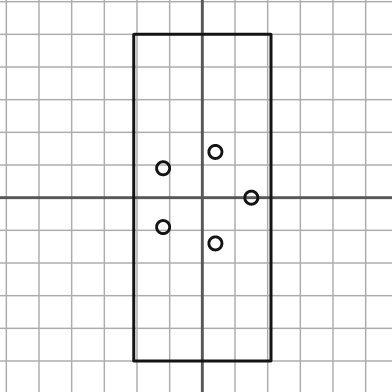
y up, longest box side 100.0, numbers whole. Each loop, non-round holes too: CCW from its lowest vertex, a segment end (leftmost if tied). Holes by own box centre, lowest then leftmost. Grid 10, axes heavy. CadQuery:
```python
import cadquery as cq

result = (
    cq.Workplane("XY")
    .moveTo(-21.0, -50.0)
    .lineTo(21.0, -50.0)
    .lineTo(21.0, 50.0)
    .lineTo(-21.0, 50.0)
    .close()
    .moveTo(4.0, -14.0)
    .circle(2.0)
    .moveTo(-12.0, -9.0)
    .circle(2.0)
    .moveTo(15.0, 0.0)
    .circle(2.0)
    .moveTo(-12.0, 9.0)
    .circle(2.0)
    .moveTo(4.0, 14.0)
    .circle(2.0)
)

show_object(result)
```